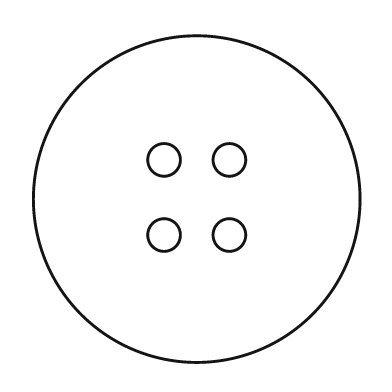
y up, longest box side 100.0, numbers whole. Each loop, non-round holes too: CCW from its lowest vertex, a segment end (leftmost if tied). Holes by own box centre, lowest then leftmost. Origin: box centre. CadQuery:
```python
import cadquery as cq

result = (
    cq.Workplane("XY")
    .moveTo(0.0, 0.0)
    .circle(50.0)
    .moveTo(-10.0, -11.0)
    .circle(5.0)
    .moveTo(10.0, -11.0)
    .circle(5.0)
    .moveTo(-10.0, 12.0)
    .circle(5.0)
    .moveTo(10.0, 12.0)
    .circle(5.0)
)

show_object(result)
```